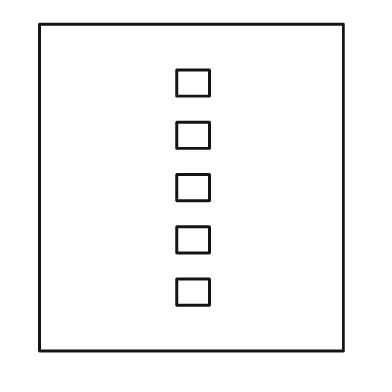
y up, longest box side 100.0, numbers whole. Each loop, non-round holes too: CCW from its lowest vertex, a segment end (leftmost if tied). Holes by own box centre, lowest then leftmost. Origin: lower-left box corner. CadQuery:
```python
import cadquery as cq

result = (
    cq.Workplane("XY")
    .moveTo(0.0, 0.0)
    .lineTo(93.0, 0.0)
    .lineTo(93.0, 100.0)
    .lineTo(0.0, 100.0)
    .close()
    .moveTo(42.0, 14.0)
    .lineTo(52.0, 14.0)
    .lineTo(52.0, 22.0)
    .lineTo(42.0, 22.0)
    .close()
    .moveTo(42.0, 30.0)
    .lineTo(52.0, 30.0)
    .lineTo(52.0, 38.0)
    .lineTo(42.0, 38.0)
    .close()
    .moveTo(42.0, 46.0)
    .lineTo(52.0, 46.0)
    .lineTo(52.0, 54.0)
    .lineTo(42.0, 54.0)
    .close()
    .moveTo(42.0, 62.0)
    .lineTo(52.0, 62.0)
    .lineTo(52.0, 70.0)
    .lineTo(42.0, 70.0)
    .close()
    .moveTo(42.0, 78.0)
    .lineTo(52.0, 78.0)
    .lineTo(52.0, 86.0)
    .lineTo(42.0, 86.0)
    .close()
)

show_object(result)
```